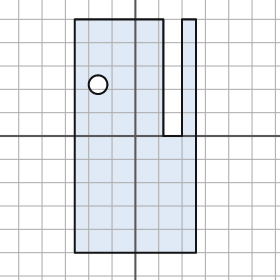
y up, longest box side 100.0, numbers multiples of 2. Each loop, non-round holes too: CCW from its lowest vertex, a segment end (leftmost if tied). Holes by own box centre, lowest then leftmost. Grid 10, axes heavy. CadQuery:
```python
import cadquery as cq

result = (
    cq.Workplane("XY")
    .moveTo(-26.0, -50.0)
    .lineTo(26.0, -50.0)
    .lineTo(26.0, 50.0)
    .lineTo(20.0, 50.0)
    .lineTo(20.0, 0.0)
    .lineTo(12.0, 0.0)
    .lineTo(12.0, 50.0)
    .lineTo(-26.0, 50.0)
    .close()
    .moveTo(-16.0, 22.0)
    .circle(4.0)
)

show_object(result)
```